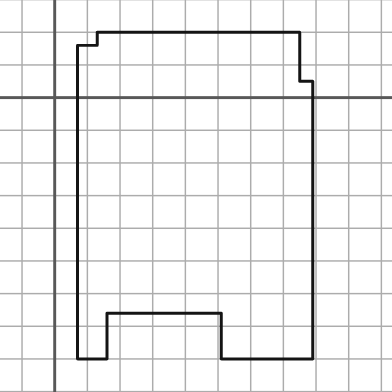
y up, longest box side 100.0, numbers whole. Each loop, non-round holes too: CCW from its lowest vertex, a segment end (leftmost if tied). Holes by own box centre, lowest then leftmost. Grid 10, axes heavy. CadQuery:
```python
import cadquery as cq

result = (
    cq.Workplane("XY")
    .moveTo(7.0, -80.0)
    .lineTo(16.0, -80.0)
    .lineTo(16.0, -66.0)
    .lineTo(51.0, -66.0)
    .lineTo(51.0, -80.0)
    .lineTo(79.0, -80.0)
    .lineTo(79.0, 5.0)
    .lineTo(75.0, 5.0)
    .lineTo(75.0, 20.0)
    .lineTo(13.0, 20.0)
    .lineTo(13.0, 16.0)
    .lineTo(7.0, 16.0)
    .close()
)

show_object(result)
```